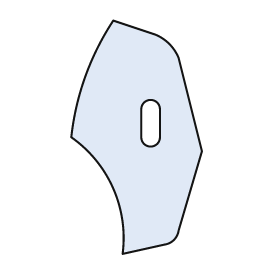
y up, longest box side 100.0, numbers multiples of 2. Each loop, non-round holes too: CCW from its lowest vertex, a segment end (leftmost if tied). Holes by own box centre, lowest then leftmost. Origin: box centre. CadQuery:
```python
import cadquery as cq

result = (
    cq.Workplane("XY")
    .moveTo(-6.0, -50.0)
    .lineTo(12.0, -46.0)
    .threePointArc((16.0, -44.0), (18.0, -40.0))
    .lineTo(28.0, -6.0)
    .lineTo(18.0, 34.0)
    .threePointArc((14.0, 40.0), (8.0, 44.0))
    .lineTo(-10.0, 50.0)
    .threePointArc((-22.0, 26.0), (-28.0, 0.0))
    .threePointArc((-10.0, -22.0), (-6.0, -50.0))
    .close()
    .moveTo(2.0, 0.0)
    .threePointArc((6.0, -4.0), (10.0, 0.0))
    .lineTo(10.0, 12.0)
    .threePointArc((6.0, 16.0), (2.0, 12.0))
    .close()
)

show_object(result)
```